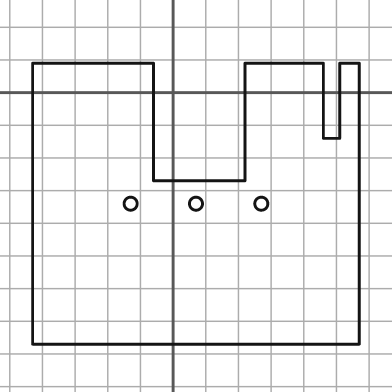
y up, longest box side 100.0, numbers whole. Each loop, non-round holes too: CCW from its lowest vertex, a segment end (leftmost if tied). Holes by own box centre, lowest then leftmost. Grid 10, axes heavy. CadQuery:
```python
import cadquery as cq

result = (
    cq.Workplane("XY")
    .moveTo(-43.0, -77.0)
    .lineTo(57.0, -77.0)
    .lineTo(57.0, 9.0)
    .lineTo(51.0, 9.0)
    .lineTo(51.0, -14.0)
    .lineTo(46.0, -14.0)
    .lineTo(46.0, 9.0)
    .lineTo(22.0, 9.0)
    .lineTo(22.0, -27.0)
    .lineTo(-6.0, -27.0)
    .lineTo(-6.0, 9.0)
    .lineTo(-43.0, 9.0)
    .close()
    .moveTo(-13.0, -34.0)
    .circle(2.0)
    .moveTo(7.0, -34.0)
    .circle(2.0)
    .moveTo(27.0, -34.0)
    .circle(2.0)
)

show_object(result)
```